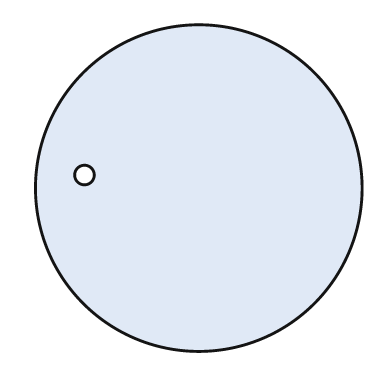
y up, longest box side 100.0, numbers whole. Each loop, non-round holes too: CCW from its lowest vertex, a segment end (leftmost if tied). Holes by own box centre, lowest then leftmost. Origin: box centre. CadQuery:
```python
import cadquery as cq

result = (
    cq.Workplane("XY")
    .moveTo(0.0, 0.0)
    .circle(50.0)
    .moveTo(-35.0, 4.0)
    .circle(3.0)
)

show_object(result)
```